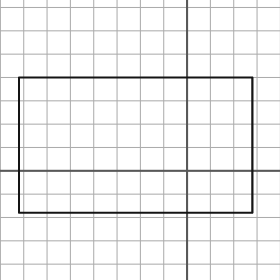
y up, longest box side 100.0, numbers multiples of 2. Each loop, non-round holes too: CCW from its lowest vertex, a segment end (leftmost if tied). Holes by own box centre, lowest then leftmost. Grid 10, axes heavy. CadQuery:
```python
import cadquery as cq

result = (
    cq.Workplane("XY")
    .moveTo(-72.0, -18.0)
    .lineTo(28.0, -18.0)
    .lineTo(28.0, 40.0)
    .lineTo(-72.0, 40.0)
    .close()
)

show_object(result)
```